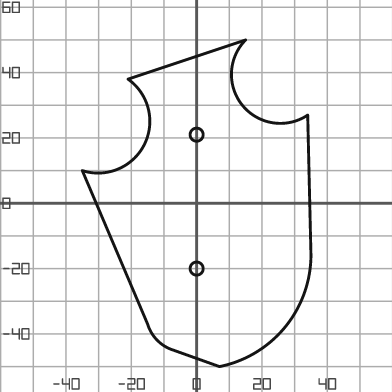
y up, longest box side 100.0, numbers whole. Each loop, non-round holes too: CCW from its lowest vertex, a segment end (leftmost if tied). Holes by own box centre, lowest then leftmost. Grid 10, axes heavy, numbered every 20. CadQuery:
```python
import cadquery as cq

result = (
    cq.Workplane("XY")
    .moveTo(7.0, -50.0)
    .threePointArc((27.0, -38.0), (35.0, -16.0))
    .lineTo(34.0, 27.0)
    .threePointArc((14.0, 30.0), (15.0, 50.0))
    .lineTo(-21.0, 38.0)
    .threePointArc((-16.0, 18.0), (-35.0, 10.0))
    .lineTo(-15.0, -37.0)
    .threePointArc((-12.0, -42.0), (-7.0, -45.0))
    .close()
    .moveTo(0.0, -20.0)
    .circle(2.0)
    .moveTo(0.0, 21.0)
    .circle(2.0)
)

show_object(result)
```